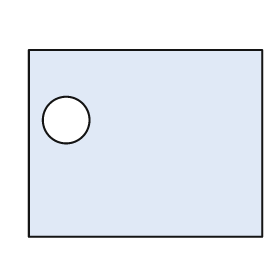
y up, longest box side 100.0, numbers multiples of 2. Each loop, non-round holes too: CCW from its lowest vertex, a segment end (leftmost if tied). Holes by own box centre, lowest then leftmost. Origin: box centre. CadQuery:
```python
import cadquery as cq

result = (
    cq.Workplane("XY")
    .moveTo(-50.0, -40.0)
    .lineTo(50.0, -40.0)
    .lineTo(50.0, 40.0)
    .lineTo(-50.0, 40.0)
    .close()
    .moveTo(-34.0, 10.0)
    .circle(10.0)
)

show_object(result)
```